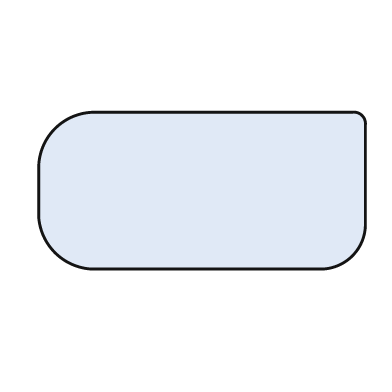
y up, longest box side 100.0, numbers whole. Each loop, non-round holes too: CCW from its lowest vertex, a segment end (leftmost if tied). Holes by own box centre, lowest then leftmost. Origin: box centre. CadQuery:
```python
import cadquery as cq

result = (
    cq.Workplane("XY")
    .moveTo(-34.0, -24.0)
    .lineTo(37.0, -24.0)
    .threePointArc((46.0, -20.0), (50.0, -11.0))
    .lineTo(50.0, 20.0)
    .threePointArc((49.0, 23.0), (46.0, 24.0))
    .lineTo(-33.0, 24.0)
    .threePointArc((-45.0, 19.0), (-50.0, 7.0))
    .lineTo(-50.0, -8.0)
    .threePointArc((-45.0, -19.0), (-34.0, -24.0))
    .close()
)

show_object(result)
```